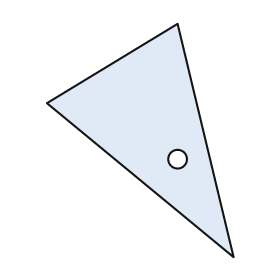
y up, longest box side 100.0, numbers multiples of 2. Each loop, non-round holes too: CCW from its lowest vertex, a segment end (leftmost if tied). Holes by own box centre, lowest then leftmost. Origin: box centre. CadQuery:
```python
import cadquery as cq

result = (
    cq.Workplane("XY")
    .moveTo(40.0, -50.0)
    .lineTo(16.0, 50.0)
    .lineTo(-40.0, 16.0)
    .close()
    .moveTo(16.0, -8.0)
    .circle(4.0)
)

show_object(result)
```